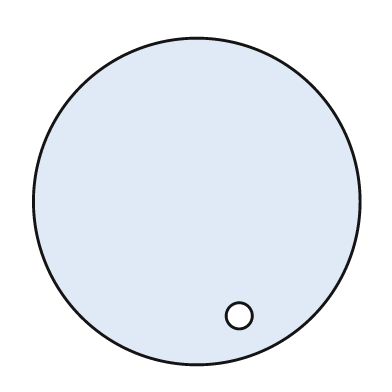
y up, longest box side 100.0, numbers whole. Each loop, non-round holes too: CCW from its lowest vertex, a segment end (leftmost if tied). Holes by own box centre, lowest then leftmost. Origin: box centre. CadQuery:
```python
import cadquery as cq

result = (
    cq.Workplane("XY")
    .moveTo(0.0, 0.0)
    .circle(50.0)
    .moveTo(13.0, -35.0)
    .circle(4.0)
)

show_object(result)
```